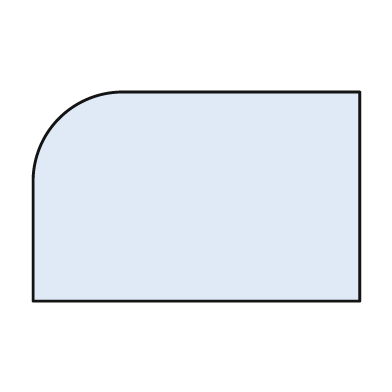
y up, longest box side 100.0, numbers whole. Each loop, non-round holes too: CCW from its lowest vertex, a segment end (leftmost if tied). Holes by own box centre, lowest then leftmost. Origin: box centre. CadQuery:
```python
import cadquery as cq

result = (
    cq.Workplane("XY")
    .moveTo(-50.0, -32.0)
    .lineTo(50.0, -32.0)
    .lineTo(50.0, 32.0)
    .lineTo(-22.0, 32.0)
    .threePointArc((-42.0, 24.0), (-50.0, 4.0))
    .close()
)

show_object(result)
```